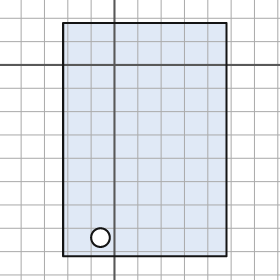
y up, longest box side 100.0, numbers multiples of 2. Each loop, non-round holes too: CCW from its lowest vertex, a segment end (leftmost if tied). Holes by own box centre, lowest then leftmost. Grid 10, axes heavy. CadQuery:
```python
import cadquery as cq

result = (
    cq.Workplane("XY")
    .moveTo(-22.0, -82.0)
    .lineTo(48.0, -82.0)
    .lineTo(48.0, 18.0)
    .lineTo(-22.0, 18.0)
    .close()
    .moveTo(-6.0, -74.0)
    .circle(4.0)
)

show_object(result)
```